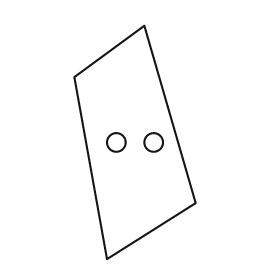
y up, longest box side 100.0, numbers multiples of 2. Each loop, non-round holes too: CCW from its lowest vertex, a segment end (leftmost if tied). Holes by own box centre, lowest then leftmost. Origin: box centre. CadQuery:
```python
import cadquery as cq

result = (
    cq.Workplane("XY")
    .moveTo(-12.0, -50.0)
    .lineTo(26.0, -26.0)
    .lineTo(4.0, 50.0)
    .lineTo(-26.0, 28.0)
    .close()
    .moveTo(-8.0, 0.0)
    .circle(4.0)
    .moveTo(8.0, 0.0)
    .circle(4.0)
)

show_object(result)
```